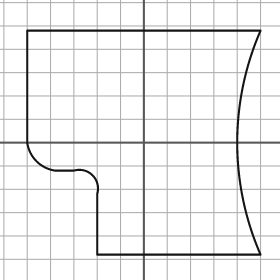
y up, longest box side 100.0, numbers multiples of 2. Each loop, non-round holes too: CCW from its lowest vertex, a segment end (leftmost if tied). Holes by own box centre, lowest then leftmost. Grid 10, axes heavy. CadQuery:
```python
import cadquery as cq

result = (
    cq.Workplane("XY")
    .moveTo(-20.0, -48.0)
    .lineTo(50.0, -48.0)
    .threePointArc((40.0, 0.0), (50.0, 48.0))
    .lineTo(-50.0, 48.0)
    .lineTo(-50.0, 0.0)
    .threePointArc((-46.0, -8.0), (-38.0, -12.0))
    .lineTo(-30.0, -12.0)
    .threePointArc((-22.0, -14.0), (-20.0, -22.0))
    .close()
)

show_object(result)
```